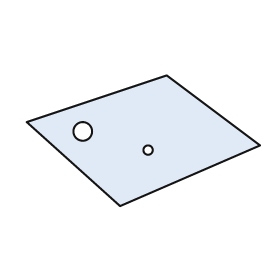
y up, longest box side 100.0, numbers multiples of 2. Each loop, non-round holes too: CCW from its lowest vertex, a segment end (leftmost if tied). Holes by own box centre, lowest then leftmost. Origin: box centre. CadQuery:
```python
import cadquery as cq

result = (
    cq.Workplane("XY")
    .moveTo(-10.0, -28.0)
    .lineTo(50.0, -2.0)
    .lineTo(10.0, 28.0)
    .lineTo(-50.0, 8.0)
    .close()
    .moveTo(2.0, -4.0)
    .circle(2.0)
    .moveTo(-26.0, 4.0)
    .circle(4.0)
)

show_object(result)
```